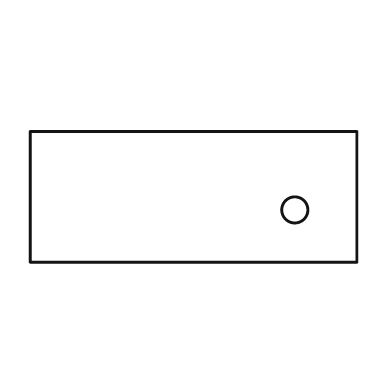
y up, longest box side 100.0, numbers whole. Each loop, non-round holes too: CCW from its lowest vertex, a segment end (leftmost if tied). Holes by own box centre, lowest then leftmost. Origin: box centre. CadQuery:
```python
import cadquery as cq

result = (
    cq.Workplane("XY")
    .moveTo(-50.0, -20.0)
    .lineTo(50.0, -20.0)
    .lineTo(50.0, 20.0)
    .lineTo(-50.0, 20.0)
    .close()
    .moveTo(31.0, -4.0)
    .circle(4.0)
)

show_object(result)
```